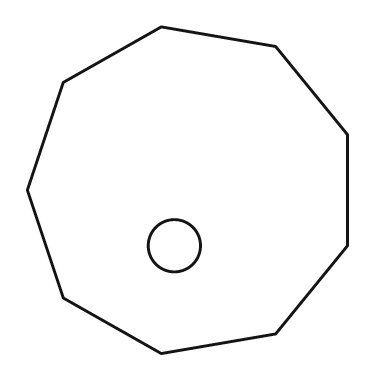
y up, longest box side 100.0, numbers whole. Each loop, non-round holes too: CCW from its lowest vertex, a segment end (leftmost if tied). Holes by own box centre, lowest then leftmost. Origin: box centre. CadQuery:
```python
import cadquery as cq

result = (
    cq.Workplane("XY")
    .moveTo(-8.0, -50.0)
    .lineTo(27.0, -44.0)
    .lineTo(49.0, -17.0)
    .lineTo(49.0, 17.0)
    .lineTo(27.0, 44.0)
    .lineTo(-8.0, 50.0)
    .lineTo(-38.0, 33.0)
    .lineTo(-49.0, 0.0)
    .lineTo(-38.0, -33.0)
    .close()
    .moveTo(-4.0, -17.0)
    .circle(8.0)
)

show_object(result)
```